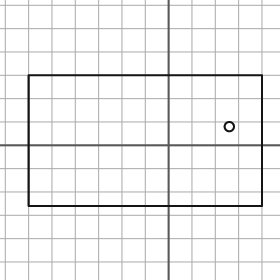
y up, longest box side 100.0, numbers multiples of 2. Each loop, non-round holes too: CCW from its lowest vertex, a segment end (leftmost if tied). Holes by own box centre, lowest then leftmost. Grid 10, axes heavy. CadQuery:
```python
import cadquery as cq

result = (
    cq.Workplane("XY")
    .moveTo(-60.0, -26.0)
    .lineTo(40.0, -26.0)
    .lineTo(40.0, 30.0)
    .lineTo(-60.0, 30.0)
    .close()
    .moveTo(26.0, 8.0)
    .circle(2.0)
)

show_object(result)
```